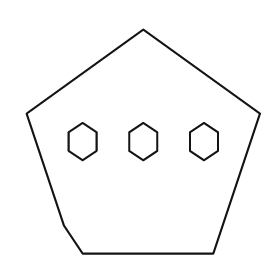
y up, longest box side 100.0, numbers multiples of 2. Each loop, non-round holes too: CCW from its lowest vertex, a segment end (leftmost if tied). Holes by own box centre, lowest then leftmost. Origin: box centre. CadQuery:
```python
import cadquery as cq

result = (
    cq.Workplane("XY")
    .moveTo(-26.0, -48.0)
    .lineTo(30.0, -48.0)
    .lineTo(50.0, 12.0)
    .lineTo(0.0, 48.0)
    .lineTo(-50.0, 12.0)
    .lineTo(-34.0, -36.0)
    .close()
    .moveTo(-26.0, -8.0)
    .lineTo(-20.0, -4.0)
    .lineTo(-20.0, 4.0)
    .lineTo(-26.0, 8.0)
    .lineTo(-32.0, 4.0)
    .lineTo(-32.0, -4.0)
    .close()
    .moveTo(0.0, -8.0)
    .lineTo(6.0, -4.0)
    .lineTo(6.0, 4.0)
    .lineTo(0.0, 8.0)
    .lineTo(-6.0, 4.0)
    .lineTo(-6.0, -4.0)
    .close()
    .moveTo(26.0, -8.0)
    .lineTo(32.0, -4.0)
    .lineTo(32.0, 4.0)
    .lineTo(26.0, 8.0)
    .lineTo(20.0, 4.0)
    .lineTo(20.0, -4.0)
    .close()
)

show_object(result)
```